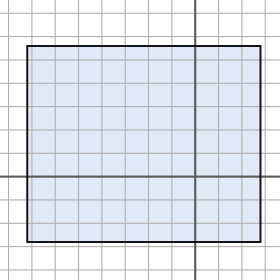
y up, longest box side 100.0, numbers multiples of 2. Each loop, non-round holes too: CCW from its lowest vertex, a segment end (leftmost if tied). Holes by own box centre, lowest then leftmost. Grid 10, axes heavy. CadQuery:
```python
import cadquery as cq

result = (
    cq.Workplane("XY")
    .moveTo(-72.0, -28.0)
    .lineTo(28.0, -28.0)
    .lineTo(28.0, 56.0)
    .lineTo(-72.0, 56.0)
    .close()
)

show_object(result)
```